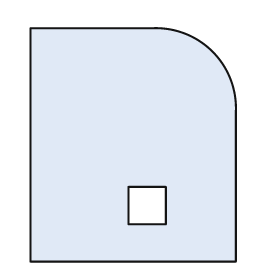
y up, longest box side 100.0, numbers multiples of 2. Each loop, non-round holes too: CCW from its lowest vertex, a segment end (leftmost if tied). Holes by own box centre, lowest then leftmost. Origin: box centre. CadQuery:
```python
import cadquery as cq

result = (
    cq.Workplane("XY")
    .moveTo(-44.0, -50.0)
    .lineTo(44.0, -50.0)
    .lineTo(44.0, 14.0)
    .threePointArc((34.0, 40.0), (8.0, 50.0))
    .lineTo(-44.0, 50.0)
    .close()
    .moveTo(-2.0, -34.0)
    .lineTo(14.0, -34.0)
    .lineTo(14.0, -18.0)
    .lineTo(-2.0, -18.0)
    .close()
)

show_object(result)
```